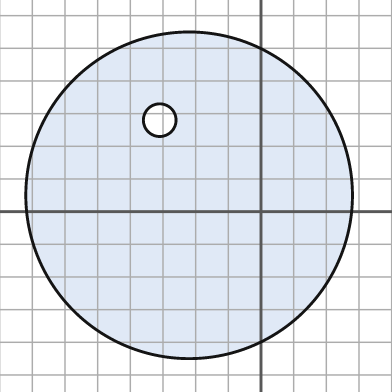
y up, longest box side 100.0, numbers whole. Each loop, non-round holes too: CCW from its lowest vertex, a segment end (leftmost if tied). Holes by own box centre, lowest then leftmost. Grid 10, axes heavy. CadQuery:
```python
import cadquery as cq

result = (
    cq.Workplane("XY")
    .moveTo(-22.0, 5.0)
    .circle(50.0)
    .moveTo(-31.0, 28.0)
    .circle(5.0)
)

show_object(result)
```